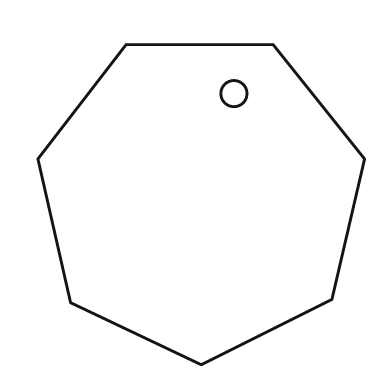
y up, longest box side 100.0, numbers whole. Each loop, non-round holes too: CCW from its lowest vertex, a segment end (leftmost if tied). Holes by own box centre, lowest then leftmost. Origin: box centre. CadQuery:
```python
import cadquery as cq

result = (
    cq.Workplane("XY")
    .moveTo(0.0, -49.0)
    .lineTo(40.0, -29.0)
    .lineTo(50.0, 14.0)
    .lineTo(22.0, 49.0)
    .lineTo(-23.0, 49.0)
    .lineTo(-50.0, 14.0)
    .lineTo(-40.0, -30.0)
    .close()
    .moveTo(10.0, 34.0)
    .circle(4.0)
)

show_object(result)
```